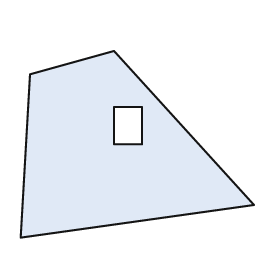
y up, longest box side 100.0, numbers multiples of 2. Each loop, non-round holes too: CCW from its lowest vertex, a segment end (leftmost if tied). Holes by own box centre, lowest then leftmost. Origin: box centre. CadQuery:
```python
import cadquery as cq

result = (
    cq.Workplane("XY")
    .moveTo(-50.0, -40.0)
    .lineTo(50.0, -26.0)
    .lineTo(-10.0, 40.0)
    .lineTo(-46.0, 30.0)
    .close()
    .moveTo(-10.0, 0.0)
    .lineTo(2.0, 0.0)
    .lineTo(2.0, 16.0)
    .lineTo(-10.0, 16.0)
    .close()
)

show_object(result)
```